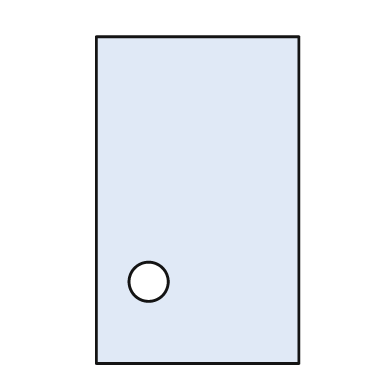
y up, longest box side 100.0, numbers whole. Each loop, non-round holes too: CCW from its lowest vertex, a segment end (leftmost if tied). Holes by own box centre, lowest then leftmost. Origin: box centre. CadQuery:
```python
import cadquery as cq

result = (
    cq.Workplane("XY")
    .moveTo(-31.0, -50.0)
    .lineTo(31.0, -50.0)
    .lineTo(31.0, 50.0)
    .lineTo(-31.0, 50.0)
    .close()
    .moveTo(-15.0, -25.0)
    .circle(6.0)
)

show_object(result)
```